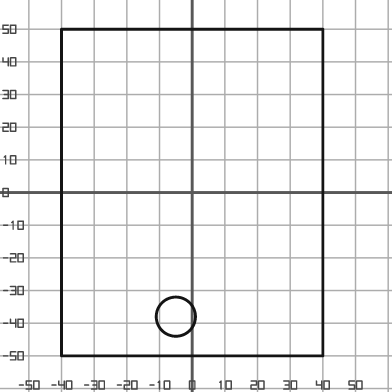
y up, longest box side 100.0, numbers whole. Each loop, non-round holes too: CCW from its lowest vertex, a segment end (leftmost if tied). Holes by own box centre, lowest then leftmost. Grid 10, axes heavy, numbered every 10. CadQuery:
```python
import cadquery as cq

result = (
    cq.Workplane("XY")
    .moveTo(-40.0, -50.0)
    .lineTo(40.0, -50.0)
    .lineTo(40.0, 50.0)
    .lineTo(-40.0, 50.0)
    .close()
    .moveTo(-5.0, -38.0)
    .circle(6.0)
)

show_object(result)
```